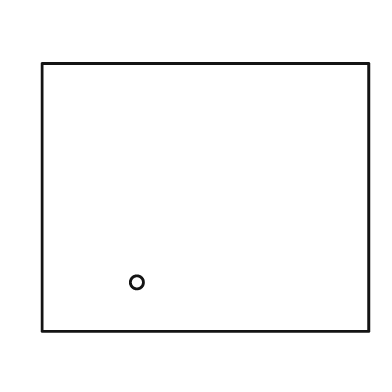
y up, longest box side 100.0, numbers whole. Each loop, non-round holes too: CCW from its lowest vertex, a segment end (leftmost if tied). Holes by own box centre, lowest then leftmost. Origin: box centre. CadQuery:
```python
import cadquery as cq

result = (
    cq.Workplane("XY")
    .moveTo(-50.0, -41.0)
    .lineTo(50.0, -41.0)
    .lineTo(50.0, 41.0)
    .lineTo(-50.0, 41.0)
    .close()
    .moveTo(-21.0, -26.0)
    .circle(2.0)
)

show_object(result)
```